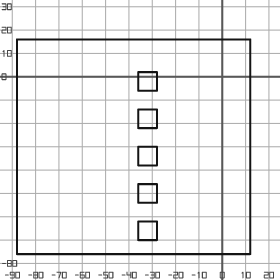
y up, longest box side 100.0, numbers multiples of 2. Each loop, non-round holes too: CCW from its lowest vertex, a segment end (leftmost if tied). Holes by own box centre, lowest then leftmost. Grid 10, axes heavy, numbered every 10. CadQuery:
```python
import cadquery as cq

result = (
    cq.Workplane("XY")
    .moveTo(-88.0, -76.0)
    .lineTo(12.0, -76.0)
    .lineTo(12.0, 16.0)
    .lineTo(-88.0, 16.0)
    .close()
    .moveTo(-36.0, -70.0)
    .lineTo(-28.0, -70.0)
    .lineTo(-28.0, -62.0)
    .lineTo(-36.0, -62.0)
    .close()
    .moveTo(-36.0, -54.0)
    .lineTo(-28.0, -54.0)
    .lineTo(-28.0, -46.0)
    .lineTo(-36.0, -46.0)
    .close()
    .moveTo(-36.0, -38.0)
    .lineTo(-28.0, -38.0)
    .lineTo(-28.0, -30.0)
    .lineTo(-36.0, -30.0)
    .close()
    .moveTo(-36.0, -22.0)
    .lineTo(-28.0, -22.0)
    .lineTo(-28.0, -14.0)
    .lineTo(-36.0, -14.0)
    .close()
    .moveTo(-36.0, -6.0)
    .lineTo(-28.0, -6.0)
    .lineTo(-28.0, 2.0)
    .lineTo(-36.0, 2.0)
    .close()
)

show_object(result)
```